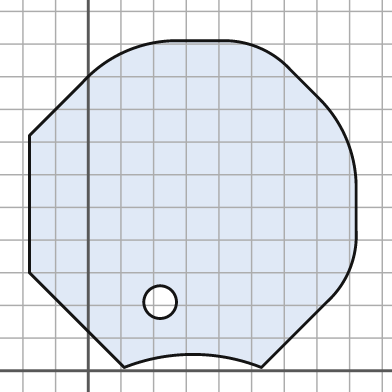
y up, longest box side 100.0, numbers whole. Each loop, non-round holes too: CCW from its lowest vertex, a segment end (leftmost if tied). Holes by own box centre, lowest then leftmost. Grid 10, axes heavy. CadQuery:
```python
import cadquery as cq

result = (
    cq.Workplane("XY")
    .moveTo(11.0, 1.0)
    .threePointArc((32.0, 5.0), (53.0, 1.0))
    .lineTo(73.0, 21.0)
    .threePointArc((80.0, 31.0), (82.0, 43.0))
    .lineTo(82.0, 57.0)
    .threePointArc((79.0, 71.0), (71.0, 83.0))
    .lineTo(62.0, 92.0)
    .threePointArc((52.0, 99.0), (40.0, 101.0))
    .lineTo(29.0, 101.0)
    .threePointArc((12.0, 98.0), (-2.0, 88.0))
    .lineTo(-18.0, 72.0)
    .lineTo(-18.0, 30.0)
    .close()
    .moveTo(22.0, 21.0)
    .circle(5.0)
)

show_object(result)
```